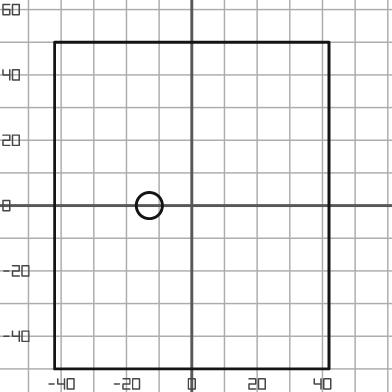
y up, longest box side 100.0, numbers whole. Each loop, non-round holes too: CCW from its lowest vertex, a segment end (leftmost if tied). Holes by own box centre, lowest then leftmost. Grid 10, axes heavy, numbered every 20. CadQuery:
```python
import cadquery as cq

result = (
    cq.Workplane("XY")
    .moveTo(-42.0, -50.0)
    .lineTo(42.0, -50.0)
    .lineTo(42.0, 50.0)
    .lineTo(-42.0, 50.0)
    .close()
    .moveTo(-13.0, 0.0)
    .circle(4.0)
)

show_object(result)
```